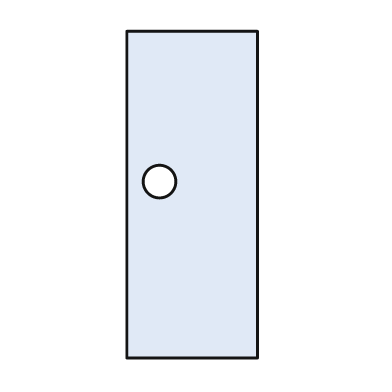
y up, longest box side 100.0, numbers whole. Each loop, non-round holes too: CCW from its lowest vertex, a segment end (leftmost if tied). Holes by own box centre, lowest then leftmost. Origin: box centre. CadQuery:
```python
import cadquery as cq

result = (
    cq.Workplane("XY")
    .moveTo(-20.0, -50.0)
    .lineTo(20.0, -50.0)
    .lineTo(20.0, 50.0)
    .lineTo(-20.0, 50.0)
    .close()
    .moveTo(-10.0, 4.0)
    .circle(5.0)
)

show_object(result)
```